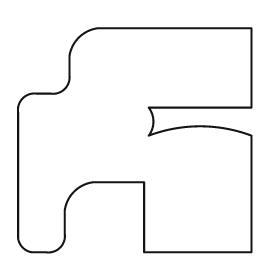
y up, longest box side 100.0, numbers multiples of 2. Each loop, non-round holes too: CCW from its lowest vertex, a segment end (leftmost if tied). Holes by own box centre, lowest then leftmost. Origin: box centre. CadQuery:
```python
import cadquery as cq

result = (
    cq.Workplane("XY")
    .moveTo(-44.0, -48.0)
    .lineTo(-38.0, -48.0)
    .threePointArc((-32.0, -46.0), (-30.0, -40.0))
    .lineTo(-30.0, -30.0)
    .threePointArc((-26.0, -22.0), (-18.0, -18.0))
    .lineTo(4.0, -18.0)
    .lineTo(4.0, -48.0)
    .lineTo(50.0, -48.0)
    .lineTo(50.0, 2.0)
    .threePointArc((28.0, 6.0), (6.0, 2.0))
    .threePointArc((8.0, 8.0), (6.0, 14.0))
    .lineTo(50.0, 14.0)
    .lineTo(50.0, 48.0)
    .lineTo(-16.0, 48.0)
    .threePointArc((-24.0, 44.0), (-28.0, 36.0))
    .lineTo(-28.0, 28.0)
    .threePointArc((-30.0, 22.0), (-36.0, 20.0))
    .lineTo(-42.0, 20.0)
    .threePointArc((-48.0, 18.0), (-50.0, 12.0))
    .lineTo(-50.0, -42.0)
    .threePointArc((-48.0, -46.0), (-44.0, -48.0))
    .close()
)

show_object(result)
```